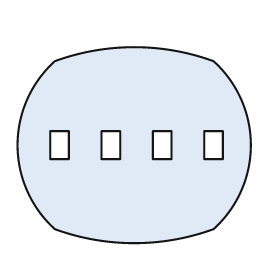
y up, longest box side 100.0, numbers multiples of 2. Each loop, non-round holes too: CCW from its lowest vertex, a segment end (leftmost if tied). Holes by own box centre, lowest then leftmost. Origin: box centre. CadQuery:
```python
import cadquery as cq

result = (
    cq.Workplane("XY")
    .moveTo(-34.0, -36.0)
    .threePointArc((0.0, -42.0), (34.0, -36.0))
    .threePointArc((50.0, 0.0), (34.0, 36.0))
    .threePointArc((0.0, 42.0), (-34.0, 36.0))
    .threePointArc((-50.0, 0.0), (-34.0, -36.0))
    .close()
    .moveTo(-36.0, -6.0)
    .lineTo(-28.0, -6.0)
    .lineTo(-28.0, 6.0)
    .lineTo(-36.0, 6.0)
    .close()
    .moveTo(-14.0, -6.0)
    .lineTo(-6.0, -6.0)
    .lineTo(-6.0, 6.0)
    .lineTo(-14.0, 6.0)
    .close()
    .moveTo(8.0, -6.0)
    .lineTo(16.0, -6.0)
    .lineTo(16.0, 6.0)
    .lineTo(8.0, 6.0)
    .close()
    .moveTo(30.0, -6.0)
    .lineTo(38.0, -6.0)
    .lineTo(38.0, 6.0)
    .lineTo(30.0, 6.0)
    .close()
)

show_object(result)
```